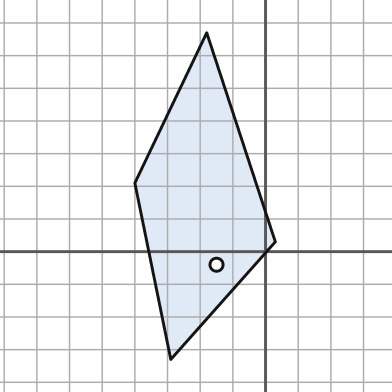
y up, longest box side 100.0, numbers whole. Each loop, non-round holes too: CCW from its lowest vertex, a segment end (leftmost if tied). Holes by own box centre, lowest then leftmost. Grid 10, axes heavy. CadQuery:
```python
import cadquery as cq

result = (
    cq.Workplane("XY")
    .moveTo(-29.0, -33.0)
    .lineTo(3.0, 3.0)
    .lineTo(-18.0, 67.0)
    .lineTo(-40.0, 21.0)
    .close()
    .moveTo(-15.0, -4.0)
    .circle(2.0)
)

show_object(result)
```